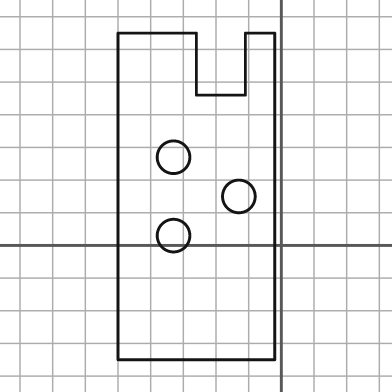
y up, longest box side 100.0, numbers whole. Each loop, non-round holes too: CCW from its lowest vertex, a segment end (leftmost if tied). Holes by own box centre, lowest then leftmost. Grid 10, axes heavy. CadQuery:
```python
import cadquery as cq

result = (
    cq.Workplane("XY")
    .moveTo(-50.0, -35.0)
    .lineTo(-2.0, -35.0)
    .lineTo(-2.0, 65.0)
    .lineTo(-11.0, 65.0)
    .lineTo(-11.0, 46.0)
    .lineTo(-26.0, 46.0)
    .lineTo(-26.0, 65.0)
    .lineTo(-50.0, 65.0)
    .close()
    .moveTo(-33.0, 3.0)
    .circle(5.0)
    .moveTo(-13.0, 15.0)
    .circle(5.0)
    .moveTo(-33.0, 27.0)
    .circle(5.0)
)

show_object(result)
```